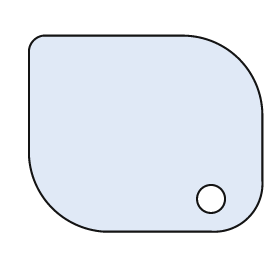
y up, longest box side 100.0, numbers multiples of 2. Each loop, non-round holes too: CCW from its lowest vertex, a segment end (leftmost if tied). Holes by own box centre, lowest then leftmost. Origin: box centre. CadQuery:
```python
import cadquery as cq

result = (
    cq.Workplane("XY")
    .moveTo(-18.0, -42.0)
    .lineTo(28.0, -42.0)
    .threePointArc((44.0, -36.0), (50.0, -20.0))
    .lineTo(50.0, 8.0)
    .threePointArc((40.0, 32.0), (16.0, 42.0))
    .lineTo(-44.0, 42.0)
    .threePointArc((-48.0, 40.0), (-50.0, 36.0))
    .lineTo(-50.0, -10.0)
    .threePointArc((-40.0, -32.0), (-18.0, -42.0))
    .close()
    .moveTo(28.0, -28.0)
    .circle(6.0)
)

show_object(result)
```